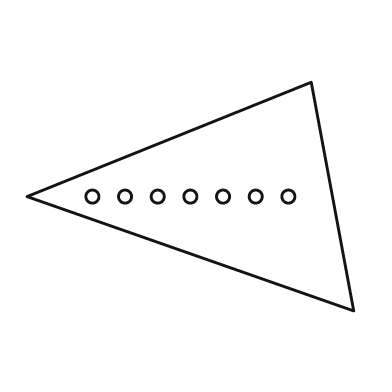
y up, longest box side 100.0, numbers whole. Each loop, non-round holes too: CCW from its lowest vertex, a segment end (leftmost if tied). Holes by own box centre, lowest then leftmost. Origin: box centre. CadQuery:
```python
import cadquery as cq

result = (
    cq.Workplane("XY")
    .moveTo(50.0, -35.0)
    .lineTo(37.0, 35.0)
    .lineTo(-50.0, 0.0)
    .close()
    .moveTo(-30.0, 0.0)
    .circle(2.0)
    .moveTo(-20.0, 0.0)
    .circle(2.0)
    .moveTo(-10.0, 0.0)
    .circle(2.0)
    .moveTo(0.0, 0.0)
    .circle(2.0)
    .moveTo(10.0, 0.0)
    .circle(2.0)
    .moveTo(20.0, 0.0)
    .circle(2.0)
    .moveTo(30.0, 0.0)
    .circle(2.0)
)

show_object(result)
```